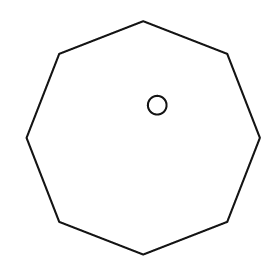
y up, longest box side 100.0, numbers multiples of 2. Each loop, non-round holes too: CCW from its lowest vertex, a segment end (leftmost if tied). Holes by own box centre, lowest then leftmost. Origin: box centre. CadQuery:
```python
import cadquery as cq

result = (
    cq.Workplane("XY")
    .moveTo(0.0, -50.0)
    .lineTo(36.0, -36.0)
    .lineTo(50.0, 0.0)
    .lineTo(36.0, 36.0)
    .lineTo(0.0, 50.0)
    .lineTo(-36.0, 36.0)
    .lineTo(-50.0, 0.0)
    .lineTo(-36.0, -36.0)
    .close()
    .moveTo(6.0, 14.0)
    .circle(4.0)
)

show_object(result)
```